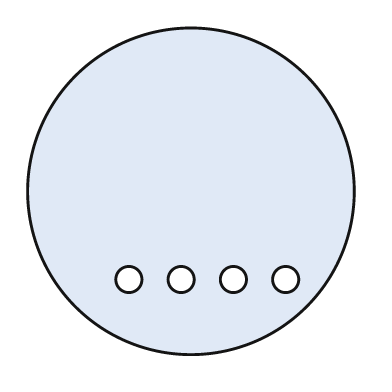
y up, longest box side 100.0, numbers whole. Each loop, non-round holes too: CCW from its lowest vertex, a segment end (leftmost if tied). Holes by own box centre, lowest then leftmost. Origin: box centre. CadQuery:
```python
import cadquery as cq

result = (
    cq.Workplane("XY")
    .moveTo(0.0, 0.0)
    .circle(50.0)
    .moveTo(-19.0, -27.0)
    .circle(4.0)
    .moveTo(-3.0, -27.0)
    .circle(4.0)
    .moveTo(13.0, -27.0)
    .circle(4.0)
    .moveTo(29.0, -27.0)
    .circle(4.0)
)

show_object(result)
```